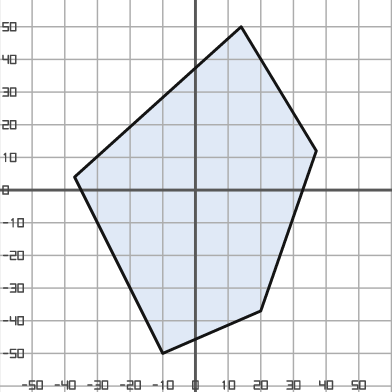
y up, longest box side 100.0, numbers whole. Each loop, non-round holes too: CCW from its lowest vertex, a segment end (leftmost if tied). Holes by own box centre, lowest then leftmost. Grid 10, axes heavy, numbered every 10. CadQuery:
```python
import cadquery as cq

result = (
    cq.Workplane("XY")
    .moveTo(-10.0, -50.0)
    .lineTo(20.0, -37.0)
    .lineTo(37.0, 12.0)
    .lineTo(14.0, 50.0)
    .lineTo(-37.0, 4.0)
    .close()
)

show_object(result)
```